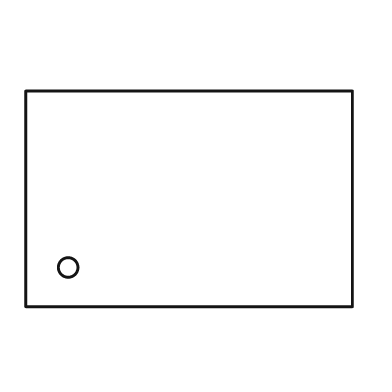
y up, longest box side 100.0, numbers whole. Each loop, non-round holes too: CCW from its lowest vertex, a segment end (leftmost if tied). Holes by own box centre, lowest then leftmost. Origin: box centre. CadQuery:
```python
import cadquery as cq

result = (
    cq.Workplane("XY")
    .moveTo(-50.0, -33.0)
    .lineTo(50.0, -33.0)
    .lineTo(50.0, 33.0)
    .lineTo(-50.0, 33.0)
    .close()
    .moveTo(-37.0, -21.0)
    .circle(3.0)
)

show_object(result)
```